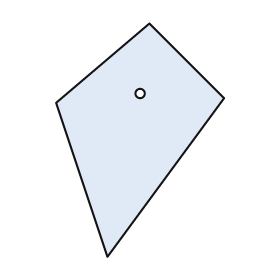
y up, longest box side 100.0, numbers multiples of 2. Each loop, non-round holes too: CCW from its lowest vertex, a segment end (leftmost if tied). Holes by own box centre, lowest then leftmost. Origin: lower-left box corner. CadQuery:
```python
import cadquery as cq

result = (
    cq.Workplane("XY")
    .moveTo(22.0, 0.0)
    .lineTo(72.0, 68.0)
    .lineTo(40.0, 100.0)
    .lineTo(0.0, 66.0)
    .close()
    .moveTo(36.0, 70.0)
    .circle(2.0)
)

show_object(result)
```